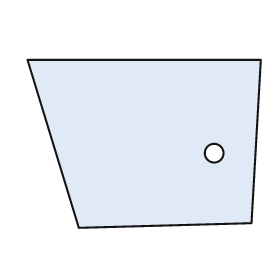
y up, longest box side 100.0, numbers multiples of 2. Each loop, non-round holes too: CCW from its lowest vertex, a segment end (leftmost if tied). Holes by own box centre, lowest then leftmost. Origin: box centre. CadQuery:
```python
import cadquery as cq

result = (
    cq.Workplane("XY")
    .moveTo(-28.0, -36.0)
    .lineTo(46.0, -34.0)
    .lineTo(50.0, 36.0)
    .lineTo(-50.0, 36.0)
    .close()
    .moveTo(30.0, -4.0)
    .circle(4.0)
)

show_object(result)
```